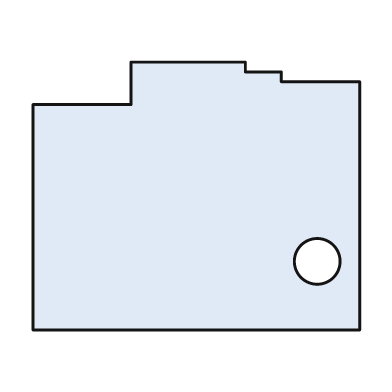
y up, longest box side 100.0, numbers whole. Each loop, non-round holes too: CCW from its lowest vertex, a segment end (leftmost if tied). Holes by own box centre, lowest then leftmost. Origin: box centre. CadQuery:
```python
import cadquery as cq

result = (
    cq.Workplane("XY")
    .moveTo(-50.0, -41.0)
    .lineTo(50.0, -41.0)
    .lineTo(50.0, 35.0)
    .lineTo(26.0, 35.0)
    .lineTo(26.0, 38.0)
    .lineTo(15.0, 38.0)
    .lineTo(15.0, 41.0)
    .lineTo(-20.0, 41.0)
    .lineTo(-20.0, 28.0)
    .lineTo(-50.0, 28.0)
    .close()
    .moveTo(37.0, -20.0)
    .circle(7.0)
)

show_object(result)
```